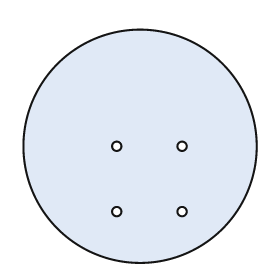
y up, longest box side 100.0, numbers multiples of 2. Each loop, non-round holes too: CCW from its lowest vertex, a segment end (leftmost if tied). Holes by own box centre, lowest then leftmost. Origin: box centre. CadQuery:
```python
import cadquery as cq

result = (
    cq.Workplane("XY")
    .moveTo(0.0, 0.0)
    .circle(50.0)
    .moveTo(-10.0, -28.0)
    .circle(2.0)
    .moveTo(18.0, -28.0)
    .circle(2.0)
    .moveTo(-10.0, 0.0)
    .circle(2.0)
    .moveTo(18.0, 0.0)
    .circle(2.0)
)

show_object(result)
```